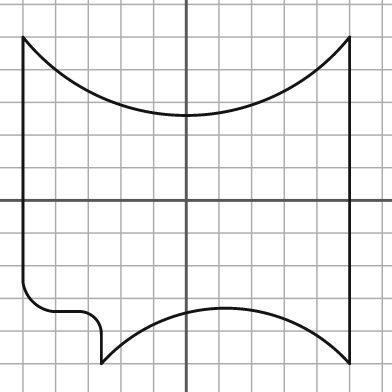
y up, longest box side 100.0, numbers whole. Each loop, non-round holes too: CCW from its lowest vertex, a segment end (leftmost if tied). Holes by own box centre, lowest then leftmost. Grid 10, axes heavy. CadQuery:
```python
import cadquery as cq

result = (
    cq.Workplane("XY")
    .moveTo(-26.0, -50.0)
    .threePointArc((12.0, -33.0), (50.0, -50.0))
    .lineTo(50.0, 50.0)
    .threePointArc((0.0, 26.0), (-50.0, 50.0))
    .lineTo(-50.0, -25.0)
    .threePointArc((-47.0, -31.0), (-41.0, -34.0))
    .lineTo(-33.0, -34.0)
    .threePointArc((-28.0, -36.0), (-26.0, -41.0))
    .close()
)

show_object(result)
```